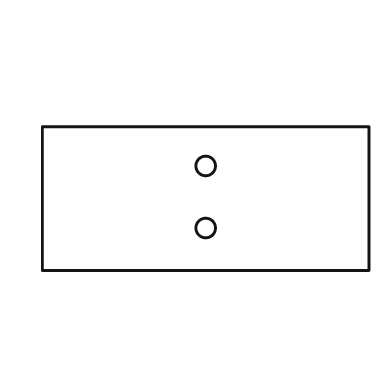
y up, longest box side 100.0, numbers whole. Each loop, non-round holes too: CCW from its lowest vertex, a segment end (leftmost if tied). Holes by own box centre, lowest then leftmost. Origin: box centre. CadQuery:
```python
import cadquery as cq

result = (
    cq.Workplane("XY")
    .moveTo(-50.0, -22.0)
    .lineTo(50.0, -22.0)
    .lineTo(50.0, 22.0)
    .lineTo(-50.0, 22.0)
    .close()
    .moveTo(0.0, -9.0)
    .circle(3.0)
    .moveTo(0.0, 10.0)
    .circle(3.0)
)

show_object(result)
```